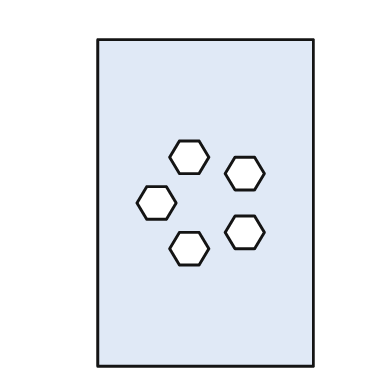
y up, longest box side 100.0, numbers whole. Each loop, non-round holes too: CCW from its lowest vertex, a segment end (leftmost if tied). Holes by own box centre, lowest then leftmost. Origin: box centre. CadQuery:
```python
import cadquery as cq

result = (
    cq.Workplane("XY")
    .moveTo(-33.0, -50.0)
    .lineTo(33.0, -50.0)
    .lineTo(33.0, 50.0)
    .lineTo(-33.0, 50.0)
    .close()
    .moveTo(-8.0, -19.0)
    .lineTo(-2.0, -19.0)
    .lineTo(1.0, -14.0)
    .lineTo(-2.0, -9.0)
    .lineTo(-8.0, -9.0)
    .lineTo(-11.0, -14.0)
    .close()
    .moveTo(9.0, -14.0)
    .lineTo(15.0, -14.0)
    .lineTo(18.0, -9.0)
    .lineTo(15.0, -4.0)
    .lineTo(9.0, -4.0)
    .lineTo(6.0, -9.0)
    .close()
    .moveTo(-18.0, -5.0)
    .lineTo(-12.0, -5.0)
    .lineTo(-9.0, 0.0)
    .lineTo(-12.0, 5.0)
    .lineTo(-18.0, 5.0)
    .lineTo(-21.0, 0.0)
    .close()
    .moveTo(9.0, 4.0)
    .lineTo(15.0, 4.0)
    .lineTo(18.0, 9.0)
    .lineTo(15.0, 14.0)
    .lineTo(9.0, 14.0)
    .lineTo(6.0, 9.0)
    .close()
    .moveTo(-8.0, 9.0)
    .lineTo(-2.0, 9.0)
    .lineTo(1.0, 14.0)
    .lineTo(-2.0, 19.0)
    .lineTo(-8.0, 19.0)
    .lineTo(-11.0, 14.0)
    .close()
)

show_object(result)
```